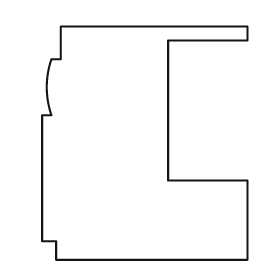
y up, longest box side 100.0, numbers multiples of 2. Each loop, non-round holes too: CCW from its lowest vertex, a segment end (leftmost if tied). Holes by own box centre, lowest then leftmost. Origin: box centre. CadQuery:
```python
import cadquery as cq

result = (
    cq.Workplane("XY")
    .moveTo(-38.0, -50.0)
    .lineTo(44.0, -50.0)
    .lineTo(44.0, -16.0)
    .lineTo(10.0, -16.0)
    .lineTo(10.0, 44.0)
    .lineTo(44.0, 44.0)
    .lineTo(44.0, 50.0)
    .lineTo(-36.0, 50.0)
    .lineTo(-36.0, 36.0)
    .lineTo(-40.0, 36.0)
    .threePointArc((-42.0, 24.0), (-40.0, 12.0))
    .lineTo(-44.0, 12.0)
    .lineTo(-44.0, -42.0)
    .lineTo(-38.0, -42.0)
    .close()
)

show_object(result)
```